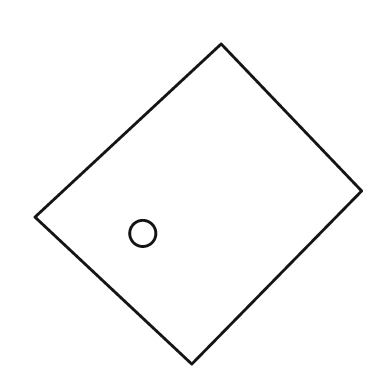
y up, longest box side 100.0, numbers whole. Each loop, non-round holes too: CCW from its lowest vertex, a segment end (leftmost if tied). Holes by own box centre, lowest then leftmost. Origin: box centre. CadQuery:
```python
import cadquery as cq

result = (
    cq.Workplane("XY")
    .moveTo(-2.0, -49.0)
    .lineTo(50.0, 4.0)
    .lineTo(7.0, 49.0)
    .lineTo(-50.0, -4.0)
    .close()
    .moveTo(-17.0, -9.0)
    .circle(4.0)
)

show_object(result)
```